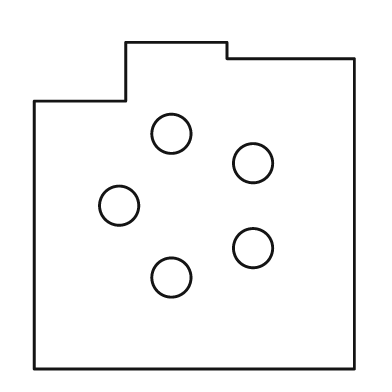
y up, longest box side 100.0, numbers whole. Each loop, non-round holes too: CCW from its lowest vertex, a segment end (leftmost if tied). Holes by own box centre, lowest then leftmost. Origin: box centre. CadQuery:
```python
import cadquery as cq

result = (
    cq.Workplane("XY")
    .moveTo(-49.0, -50.0)
    .lineTo(49.0, -50.0)
    .lineTo(49.0, 45.0)
    .lineTo(10.0, 45.0)
    .lineTo(10.0, 50.0)
    .lineTo(-21.0, 50.0)
    .lineTo(-21.0, 32.0)
    .lineTo(-49.0, 32.0)
    .close()
    .moveTo(-7.0, -22.0)
    .circle(6.0)
    .moveTo(18.0, -13.0)
    .circle(6.0)
    .moveTo(-23.0, 0.0)
    .circle(6.0)
    .moveTo(18.0, 13.0)
    .circle(6.0)
    .moveTo(-7.0, 22.0)
    .circle(6.0)
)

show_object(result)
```